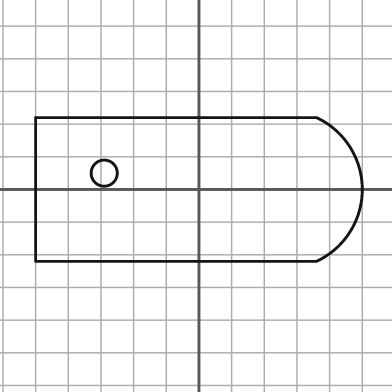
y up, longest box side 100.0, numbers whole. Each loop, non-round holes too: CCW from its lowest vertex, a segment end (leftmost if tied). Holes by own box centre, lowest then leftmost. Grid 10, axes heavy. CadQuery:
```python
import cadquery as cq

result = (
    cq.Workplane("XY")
    .moveTo(-50.0, -22.0)
    .lineTo(36.0, -22.0)
    .threePointArc((50.0, 0.0), (36.0, 22.0))
    .lineTo(-50.0, 22.0)
    .close()
    .moveTo(-29.0, 5.0)
    .circle(4.0)
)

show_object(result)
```